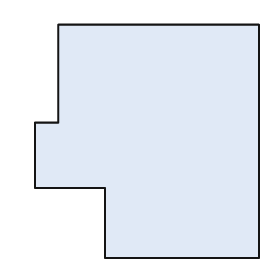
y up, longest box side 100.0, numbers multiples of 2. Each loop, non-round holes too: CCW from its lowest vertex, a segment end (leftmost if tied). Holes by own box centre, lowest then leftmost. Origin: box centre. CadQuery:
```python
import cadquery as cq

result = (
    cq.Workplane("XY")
    .moveTo(-18.0, -50.0)
    .lineTo(48.0, -50.0)
    .lineTo(48.0, 50.0)
    .lineTo(-38.0, 50.0)
    .lineTo(-38.0, 8.0)
    .lineTo(-48.0, 8.0)
    .lineTo(-48.0, -20.0)
    .lineTo(-18.0, -20.0)
    .close()
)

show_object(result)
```